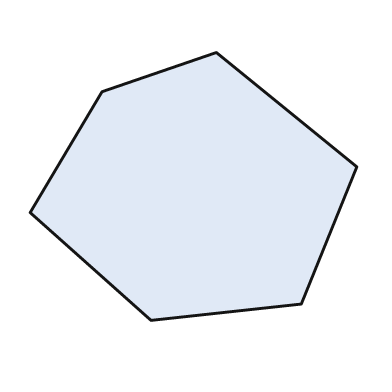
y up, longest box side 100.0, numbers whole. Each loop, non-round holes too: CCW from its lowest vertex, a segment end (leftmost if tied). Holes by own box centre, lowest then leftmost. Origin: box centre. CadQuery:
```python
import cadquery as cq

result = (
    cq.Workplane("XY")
    .moveTo(-13.0, -41.0)
    .lineTo(33.0, -36.0)
    .lineTo(50.0, 6.0)
    .lineTo(7.0, 41.0)
    .lineTo(-28.0, 29.0)
    .lineTo(-50.0, -8.0)
    .close()
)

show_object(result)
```